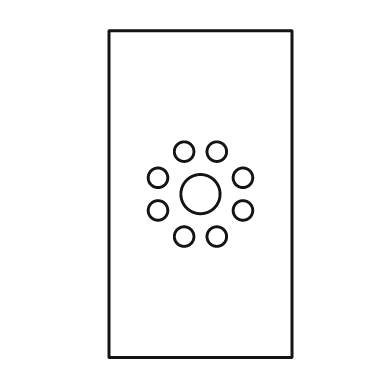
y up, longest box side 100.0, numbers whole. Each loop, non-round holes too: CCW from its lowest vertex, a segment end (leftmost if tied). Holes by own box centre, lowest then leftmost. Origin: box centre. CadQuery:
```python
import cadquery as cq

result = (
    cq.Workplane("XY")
    .moveTo(-28.0, -50.0)
    .lineTo(28.0, -50.0)
    .lineTo(28.0, 50.0)
    .lineTo(-28.0, 50.0)
    .close()
    .moveTo(-5.0, -13.0)
    .circle(3.0)
    .moveTo(5.0, -13.0)
    .circle(3.0)
    .moveTo(-13.0, -5.0)
    .circle(3.0)
    .moveTo(13.0, -5.0)
    .circle(3.0)
    .moveTo(0.0, 0.0)
    .circle(6.0)
    .moveTo(-13.0, 5.0)
    .circle(3.0)
    .moveTo(13.0, 5.0)
    .circle(3.0)
    .moveTo(-5.0, 13.0)
    .circle(3.0)
    .moveTo(5.0, 13.0)
    .circle(3.0)
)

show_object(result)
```